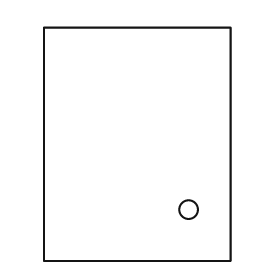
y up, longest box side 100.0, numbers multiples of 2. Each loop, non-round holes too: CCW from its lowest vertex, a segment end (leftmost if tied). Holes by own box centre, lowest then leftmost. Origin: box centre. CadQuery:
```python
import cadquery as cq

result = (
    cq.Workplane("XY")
    .moveTo(-40.0, -50.0)
    .lineTo(40.0, -50.0)
    .lineTo(40.0, 50.0)
    .lineTo(-40.0, 50.0)
    .close()
    .moveTo(22.0, -28.0)
    .circle(4.0)
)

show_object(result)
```